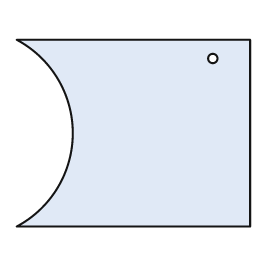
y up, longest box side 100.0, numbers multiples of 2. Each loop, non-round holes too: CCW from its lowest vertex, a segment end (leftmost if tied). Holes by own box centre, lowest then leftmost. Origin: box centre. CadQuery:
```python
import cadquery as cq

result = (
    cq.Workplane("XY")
    .moveTo(-50.0, -40.0)
    .lineTo(50.0, -40.0)
    .lineTo(50.0, 40.0)
    .lineTo(-50.0, 40.0)
    .threePointArc((-26.0, 0.0), (-50.0, -40.0))
    .close()
    .moveTo(34.0, 32.0)
    .circle(2.0)
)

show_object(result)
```